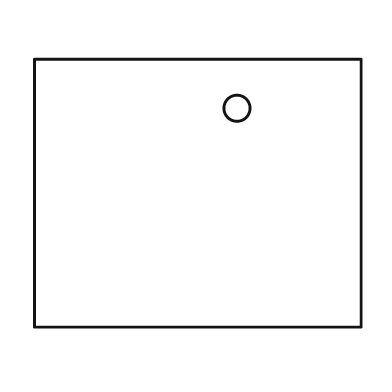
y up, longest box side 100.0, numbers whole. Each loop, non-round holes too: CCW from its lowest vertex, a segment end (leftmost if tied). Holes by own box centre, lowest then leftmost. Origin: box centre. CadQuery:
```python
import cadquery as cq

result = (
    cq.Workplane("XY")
    .moveTo(-50.0, -41.0)
    .lineTo(50.0, -41.0)
    .lineTo(50.0, 41.0)
    .lineTo(-50.0, 41.0)
    .close()
    .moveTo(12.0, 26.0)
    .circle(4.0)
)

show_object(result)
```